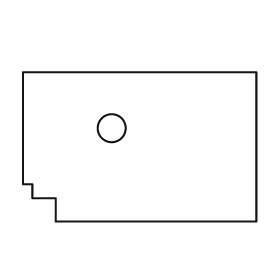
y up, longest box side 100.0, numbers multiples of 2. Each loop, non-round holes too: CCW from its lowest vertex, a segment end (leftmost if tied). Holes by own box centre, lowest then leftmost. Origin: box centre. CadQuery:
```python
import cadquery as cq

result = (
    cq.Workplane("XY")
    .moveTo(-36.0, -32.0)
    .lineTo(50.0, -32.0)
    .lineTo(50.0, 32.0)
    .lineTo(-50.0, 32.0)
    .lineTo(-50.0, -16.0)
    .lineTo(-46.0, -16.0)
    .lineTo(-46.0, -22.0)
    .lineTo(-36.0, -22.0)
    .close()
    .moveTo(-12.0, 8.0)
    .circle(6.0)
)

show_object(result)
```